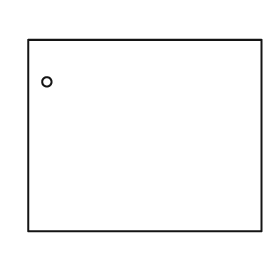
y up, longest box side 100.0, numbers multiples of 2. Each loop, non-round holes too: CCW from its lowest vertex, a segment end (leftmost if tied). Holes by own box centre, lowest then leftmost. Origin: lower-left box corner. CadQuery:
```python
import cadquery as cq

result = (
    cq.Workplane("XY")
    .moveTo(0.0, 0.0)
    .lineTo(100.0, 0.0)
    .lineTo(100.0, 82.0)
    .lineTo(0.0, 82.0)
    .close()
    .moveTo(8.0, 64.0)
    .circle(2.0)
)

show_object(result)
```